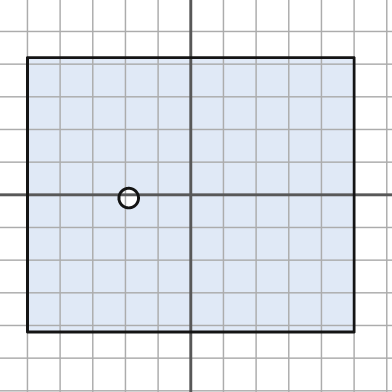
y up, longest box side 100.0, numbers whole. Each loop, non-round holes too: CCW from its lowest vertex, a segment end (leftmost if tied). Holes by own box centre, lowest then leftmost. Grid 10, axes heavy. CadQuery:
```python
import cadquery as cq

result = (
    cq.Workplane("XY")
    .moveTo(-50.0, -42.0)
    .lineTo(50.0, -42.0)
    .lineTo(50.0, 42.0)
    .lineTo(-50.0, 42.0)
    .close()
    .moveTo(-19.0, -1.0)
    .circle(3.0)
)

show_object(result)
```